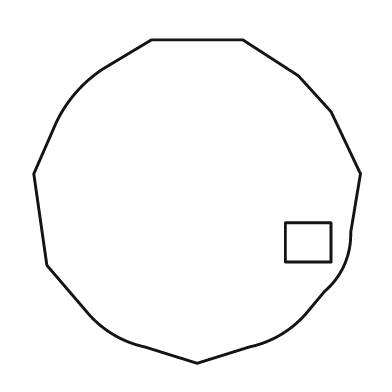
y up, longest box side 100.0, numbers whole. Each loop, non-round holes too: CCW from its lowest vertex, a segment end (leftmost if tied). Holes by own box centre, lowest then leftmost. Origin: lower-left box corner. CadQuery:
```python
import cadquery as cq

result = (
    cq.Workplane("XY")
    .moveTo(50.0, 0.0)
    .lineTo(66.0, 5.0)
    .threePointArc((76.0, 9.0), (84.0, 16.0))
    .lineTo(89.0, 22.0)
    .threePointArc((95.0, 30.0), (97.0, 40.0))
    .lineTo(100.0, 58.0)
    .lineTo(91.0, 77.0)
    .lineTo(81.0, 88.0)
    .lineTo(64.0, 99.0)
    .lineTo(36.0, 99.0)
    .lineTo(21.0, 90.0)
    .threePointArc((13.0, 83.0), (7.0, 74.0))
    .lineTo(0.0, 58.0)
    .lineTo(4.0, 30.0)
    .lineTo(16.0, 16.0)
    .threePointArc((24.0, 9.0), (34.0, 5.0))
    .close()
    .moveTo(77.0, 31.0)
    .lineTo(91.0, 31.0)
    .lineTo(91.0, 43.0)
    .lineTo(77.0, 43.0)
    .close()
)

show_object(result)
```